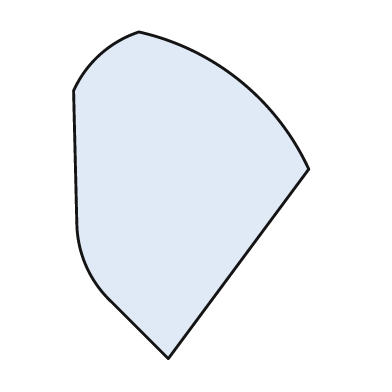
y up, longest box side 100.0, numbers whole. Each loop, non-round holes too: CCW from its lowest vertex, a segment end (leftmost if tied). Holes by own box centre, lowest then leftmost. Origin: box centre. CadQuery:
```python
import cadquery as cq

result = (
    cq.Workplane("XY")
    .moveTo(-7.0, -50.0)
    .lineTo(36.0, 8.0)
    .threePointArc((15.0, 35.0), (-16.0, 50.0))
    .threePointArc((-28.0, 43.0), (-36.0, 32.0))
    .lineTo(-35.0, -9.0)
    .threePointArc((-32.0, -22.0), (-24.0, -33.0))
    .close()
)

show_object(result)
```